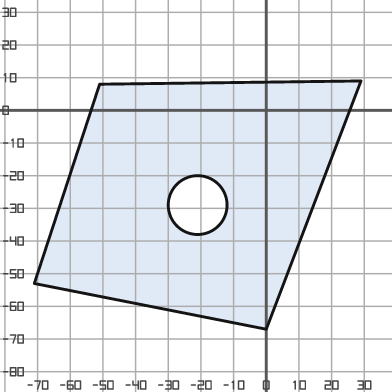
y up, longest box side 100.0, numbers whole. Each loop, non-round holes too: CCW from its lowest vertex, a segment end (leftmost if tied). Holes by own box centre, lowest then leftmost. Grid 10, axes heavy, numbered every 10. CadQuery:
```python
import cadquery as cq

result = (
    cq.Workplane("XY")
    .moveTo(0.0, -67.0)
    .lineTo(29.0, 9.0)
    .lineTo(-51.0, 8.0)
    .lineTo(-71.0, -53.0)
    .close()
    .moveTo(-21.0, -29.0)
    .circle(9.0)
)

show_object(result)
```